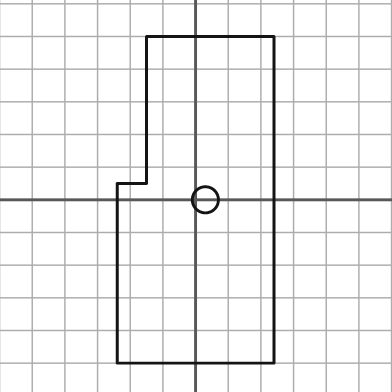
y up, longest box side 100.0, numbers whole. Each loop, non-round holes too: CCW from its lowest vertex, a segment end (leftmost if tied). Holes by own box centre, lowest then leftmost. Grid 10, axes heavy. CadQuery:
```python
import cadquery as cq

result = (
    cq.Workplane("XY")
    .moveTo(-24.0, -50.0)
    .lineTo(24.0, -50.0)
    .lineTo(24.0, 50.0)
    .lineTo(-15.0, 50.0)
    .lineTo(-15.0, 5.0)
    .lineTo(-24.0, 5.0)
    .close()
    .moveTo(3.0, 0.0)
    .circle(4.0)
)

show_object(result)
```